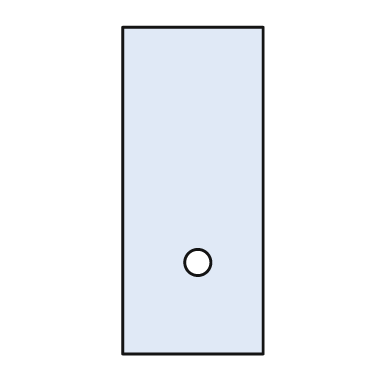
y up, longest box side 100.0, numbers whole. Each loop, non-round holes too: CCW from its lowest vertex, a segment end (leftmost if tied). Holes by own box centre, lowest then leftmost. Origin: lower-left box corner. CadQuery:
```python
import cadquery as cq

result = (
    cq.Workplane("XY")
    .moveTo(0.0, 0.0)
    .lineTo(43.0, 0.0)
    .lineTo(43.0, 100.0)
    .lineTo(0.0, 100.0)
    .close()
    .moveTo(23.0, 28.0)
    .circle(4.0)
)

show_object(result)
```